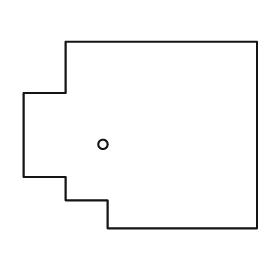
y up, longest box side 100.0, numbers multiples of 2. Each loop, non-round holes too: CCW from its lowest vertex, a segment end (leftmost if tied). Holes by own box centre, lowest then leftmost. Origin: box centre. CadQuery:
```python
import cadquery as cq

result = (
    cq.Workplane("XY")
    .moveTo(-14.0, -40.0)
    .lineTo(50.0, -40.0)
    .lineTo(50.0, 40.0)
    .lineTo(-32.0, 40.0)
    .lineTo(-32.0, 18.0)
    .lineTo(-50.0, 18.0)
    .lineTo(-50.0, -18.0)
    .lineTo(-32.0, -18.0)
    .lineTo(-32.0, -28.0)
    .lineTo(-14.0, -28.0)
    .close()
    .moveTo(-16.0, -4.0)
    .circle(2.0)
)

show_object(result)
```